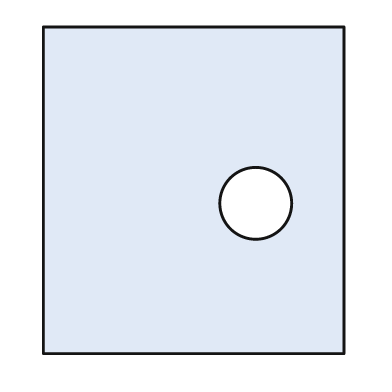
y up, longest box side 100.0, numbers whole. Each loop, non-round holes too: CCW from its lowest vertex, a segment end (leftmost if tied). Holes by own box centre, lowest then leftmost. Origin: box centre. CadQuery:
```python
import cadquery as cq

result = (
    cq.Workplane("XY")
    .moveTo(-46.0, -50.0)
    .lineTo(46.0, -50.0)
    .lineTo(46.0, 50.0)
    .lineTo(-46.0, 50.0)
    .close()
    .moveTo(19.0, -4.0)
    .circle(11.0)
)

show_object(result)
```